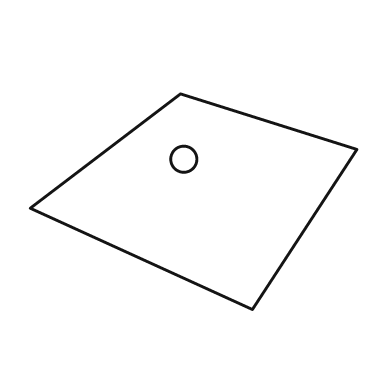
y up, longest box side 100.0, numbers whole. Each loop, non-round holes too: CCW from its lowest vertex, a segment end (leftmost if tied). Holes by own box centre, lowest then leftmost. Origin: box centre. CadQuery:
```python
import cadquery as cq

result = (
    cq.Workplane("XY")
    .moveTo(18.0, -33.0)
    .lineTo(50.0, 16.0)
    .lineTo(-4.0, 33.0)
    .lineTo(-50.0, -2.0)
    .close()
    .moveTo(-3.0, 13.0)
    .circle(4.0)
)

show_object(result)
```